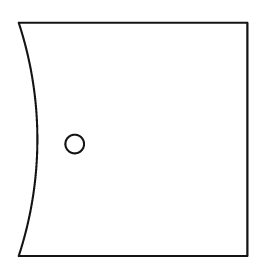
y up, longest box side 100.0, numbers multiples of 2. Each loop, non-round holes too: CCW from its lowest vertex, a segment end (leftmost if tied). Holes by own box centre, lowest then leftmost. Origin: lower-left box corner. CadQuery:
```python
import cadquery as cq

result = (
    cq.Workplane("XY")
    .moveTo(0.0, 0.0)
    .lineTo(98.0, 0.0)
    .lineTo(98.0, 100.0)
    .lineTo(0.0, 100.0)
    .threePointArc((8.0, 50.0), (0.0, 0.0))
    .close()
    .moveTo(24.0, 48.0)
    .circle(4.0)
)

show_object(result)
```